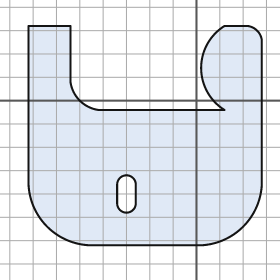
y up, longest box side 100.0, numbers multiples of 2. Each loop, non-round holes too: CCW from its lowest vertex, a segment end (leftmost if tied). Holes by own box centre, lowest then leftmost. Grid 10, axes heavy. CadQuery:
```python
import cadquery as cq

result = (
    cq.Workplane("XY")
    .moveTo(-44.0, -62.0)
    .lineTo(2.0, -62.0)
    .threePointArc((20.0, -54.0), (28.0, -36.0))
    .lineTo(28.0, 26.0)
    .threePointArc((26.0, 30.0), (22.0, 32.0))
    .lineTo(12.0, 32.0)
    .threePointArc((2.0, 14.0), (12.0, -4.0))
    .lineTo(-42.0, -4.0)
    .threePointArc((-50.0, 0.0), (-54.0, 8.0))
    .lineTo(-54.0, 32.0)
    .lineTo(-72.0, 32.0)
    .lineTo(-72.0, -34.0)
    .threePointArc((-64.0, -54.0), (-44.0, -62.0))
    .close()
    .moveTo(-34.0, -44.0)
    .threePointArc((-30.0, -48.0), (-26.0, -44.0))
    .lineTo(-26.0, -36.0)
    .threePointArc((-30.0, -32.0), (-34.0, -36.0))
    .close()
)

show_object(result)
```